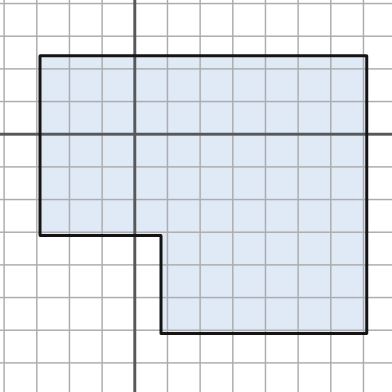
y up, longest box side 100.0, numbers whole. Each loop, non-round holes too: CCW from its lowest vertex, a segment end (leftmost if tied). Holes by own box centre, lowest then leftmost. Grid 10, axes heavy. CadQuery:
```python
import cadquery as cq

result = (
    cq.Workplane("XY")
    .moveTo(8.0, -61.0)
    .lineTo(71.0, -61.0)
    .lineTo(71.0, 24.0)
    .lineTo(-29.0, 24.0)
    .lineTo(-29.0, -31.0)
    .lineTo(8.0, -31.0)
    .close()
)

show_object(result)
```